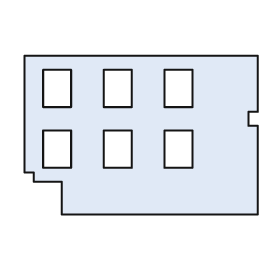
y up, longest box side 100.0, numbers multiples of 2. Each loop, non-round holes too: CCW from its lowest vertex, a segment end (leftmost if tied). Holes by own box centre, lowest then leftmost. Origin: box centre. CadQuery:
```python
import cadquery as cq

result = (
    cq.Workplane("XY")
    .moveTo(-34.0, -34.0)
    .lineTo(50.0, -34.0)
    .lineTo(50.0, 4.0)
    .lineTo(46.0, 4.0)
    .lineTo(46.0, 10.0)
    .lineTo(50.0, 10.0)
    .lineTo(50.0, 34.0)
    .lineTo(-50.0, 34.0)
    .lineTo(-50.0, -16.0)
    .lineTo(-46.0, -16.0)
    .lineTo(-46.0, -20.0)
    .lineTo(-34.0, -20.0)
    .close()
    .moveTo(-42.0, -14.0)
    .lineTo(-30.0, -14.0)
    .lineTo(-30.0, 2.0)
    .lineTo(-42.0, 2.0)
    .close()
    .moveTo(-16.0, -14.0)
    .lineTo(-4.0, -14.0)
    .lineTo(-4.0, 2.0)
    .lineTo(-16.0, 2.0)
    .close()
    .moveTo(10.0, -14.0)
    .lineTo(22.0, -14.0)
    .lineTo(22.0, 2.0)
    .lineTo(10.0, 2.0)
    .close()
    .moveTo(-42.0, 12.0)
    .lineTo(-30.0, 12.0)
    .lineTo(-30.0, 28.0)
    .lineTo(-42.0, 28.0)
    .close()
    .moveTo(-16.0, 12.0)
    .lineTo(-4.0, 12.0)
    .lineTo(-4.0, 28.0)
    .lineTo(-16.0, 28.0)
    .close()
    .moveTo(10.0, 12.0)
    .lineTo(22.0, 12.0)
    .lineTo(22.0, 28.0)
    .lineTo(10.0, 28.0)
    .close()
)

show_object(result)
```